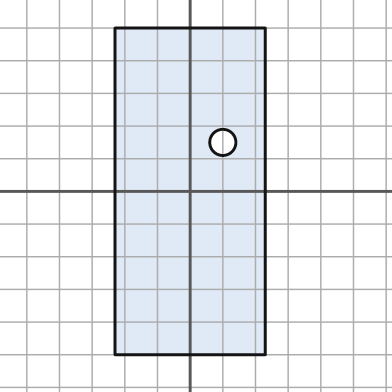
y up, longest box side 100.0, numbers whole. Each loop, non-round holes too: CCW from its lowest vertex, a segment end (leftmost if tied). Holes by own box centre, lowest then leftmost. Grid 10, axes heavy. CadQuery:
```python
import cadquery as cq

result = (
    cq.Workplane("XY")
    .moveTo(-23.0, -50.0)
    .lineTo(23.0, -50.0)
    .lineTo(23.0, 50.0)
    .lineTo(-23.0, 50.0)
    .close()
    .moveTo(10.0, 15.0)
    .circle(4.0)
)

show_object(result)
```